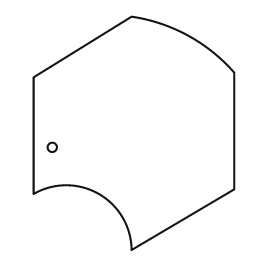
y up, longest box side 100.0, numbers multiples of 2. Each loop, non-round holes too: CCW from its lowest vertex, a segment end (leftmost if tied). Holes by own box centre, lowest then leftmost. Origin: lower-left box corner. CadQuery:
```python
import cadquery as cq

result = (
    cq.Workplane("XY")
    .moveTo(42.0, 0.0)
    .lineTo(86.0, 26.0)
    .lineTo(86.0, 76.0)
    .threePointArc((66.0, 92.0), (42.0, 100.0))
    .lineTo(0.0, 74.0)
    .lineTo(0.0, 24.0)
    .threePointArc((28.0, 24.0), (42.0, 0.0))
    .close()
    .moveTo(8.0, 44.0)
    .circle(2.0)
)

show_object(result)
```